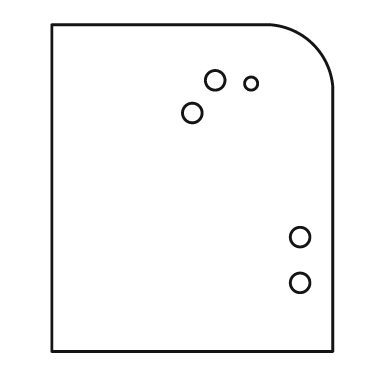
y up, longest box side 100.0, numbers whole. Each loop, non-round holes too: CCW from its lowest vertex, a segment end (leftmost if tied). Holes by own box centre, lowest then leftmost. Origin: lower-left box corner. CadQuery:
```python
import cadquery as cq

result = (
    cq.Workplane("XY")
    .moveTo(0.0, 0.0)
    .lineTo(86.0, 0.0)
    .lineTo(86.0, 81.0)
    .threePointArc((80.0, 94.0), (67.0, 100.0))
    .lineTo(0.0, 100.0)
    .close()
    .moveTo(76.0, 21.0)
    .circle(3.0)
    .moveTo(76.0, 35.0)
    .circle(3.0)
    .moveTo(43.0, 73.0)
    .circle(3.0)
    .moveTo(61.0, 82.0)
    .circle(2.0)
    .moveTo(50.0, 83.0)
    .circle(3.0)
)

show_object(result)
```